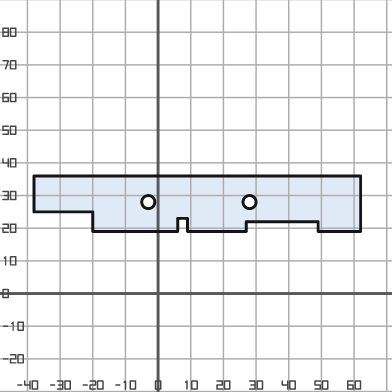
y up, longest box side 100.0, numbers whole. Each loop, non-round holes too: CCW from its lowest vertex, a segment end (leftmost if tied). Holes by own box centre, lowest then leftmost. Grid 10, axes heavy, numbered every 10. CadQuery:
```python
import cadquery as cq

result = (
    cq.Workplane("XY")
    .moveTo(-20.0, 19.0)
    .lineTo(6.0, 19.0)
    .lineTo(6.0, 23.0)
    .lineTo(9.0, 23.0)
    .lineTo(9.0, 19.0)
    .lineTo(27.0, 19.0)
    .lineTo(27.0, 22.0)
    .lineTo(49.0, 22.0)
    .lineTo(49.0, 19.0)
    .lineTo(62.0, 19.0)
    .lineTo(62.0, 36.0)
    .lineTo(-38.0, 36.0)
    .lineTo(-38.0, 25.0)
    .lineTo(-20.0, 25.0)
    .close()
    .moveTo(-3.0, 28.0)
    .circle(2.0)
    .moveTo(28.0, 28.0)
    .circle(2.0)
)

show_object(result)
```